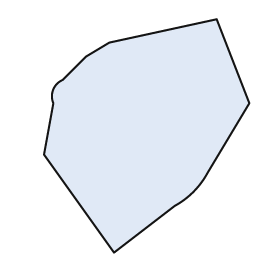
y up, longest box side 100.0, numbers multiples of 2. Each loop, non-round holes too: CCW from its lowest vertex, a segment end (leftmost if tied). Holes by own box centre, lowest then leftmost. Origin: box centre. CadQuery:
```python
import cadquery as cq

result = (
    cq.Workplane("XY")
    .moveTo(-14.0, -50.0)
    .lineTo(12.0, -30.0)
    .threePointArc((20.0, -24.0), (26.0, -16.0))
    .lineTo(44.0, 14.0)
    .lineTo(30.0, 50.0)
    .lineTo(-16.0, 40.0)
    .lineTo(-26.0, 34.0)
    .lineTo(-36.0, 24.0)
    .threePointArc((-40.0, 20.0), (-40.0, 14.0))
    .lineTo(-44.0, -8.0)
    .close()
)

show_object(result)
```